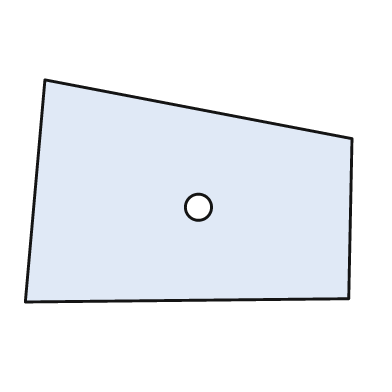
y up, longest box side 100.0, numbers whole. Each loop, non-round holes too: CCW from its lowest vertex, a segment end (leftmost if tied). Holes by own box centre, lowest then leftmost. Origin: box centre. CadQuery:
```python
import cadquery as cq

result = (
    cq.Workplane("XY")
    .moveTo(-50.0, -34.0)
    .lineTo(49.0, -33.0)
    .lineTo(50.0, 16.0)
    .lineTo(-44.0, 34.0)
    .close()
    .moveTo(3.0, -5.0)
    .circle(4.0)
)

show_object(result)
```